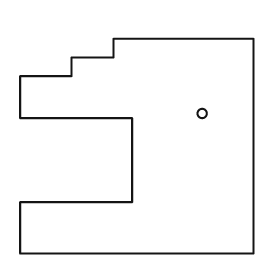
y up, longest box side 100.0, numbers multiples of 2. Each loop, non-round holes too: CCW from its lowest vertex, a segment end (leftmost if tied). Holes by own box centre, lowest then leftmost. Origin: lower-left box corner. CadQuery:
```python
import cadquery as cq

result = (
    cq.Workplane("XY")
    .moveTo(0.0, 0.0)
    .lineTo(100.0, 0.0)
    .lineTo(100.0, 92.0)
    .lineTo(40.0, 92.0)
    .lineTo(40.0, 84.0)
    .lineTo(22.0, 84.0)
    .lineTo(22.0, 76.0)
    .lineTo(0.0, 76.0)
    .lineTo(0.0, 58.0)
    .lineTo(48.0, 58.0)
    .lineTo(48.0, 22.0)
    .lineTo(0.0, 22.0)
    .close()
    .moveTo(78.0, 60.0)
    .circle(2.0)
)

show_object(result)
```